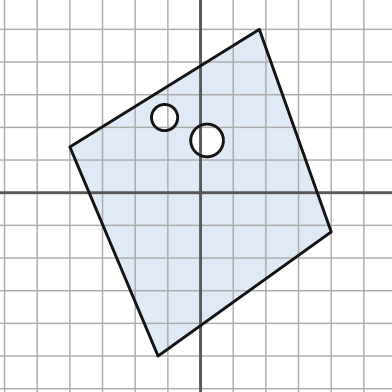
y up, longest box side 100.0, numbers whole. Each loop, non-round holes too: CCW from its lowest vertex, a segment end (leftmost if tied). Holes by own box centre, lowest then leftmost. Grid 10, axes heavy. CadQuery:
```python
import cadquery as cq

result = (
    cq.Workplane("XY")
    .moveTo(-13.0, -50.0)
    .lineTo(40.0, -12.0)
    .lineTo(18.0, 50.0)
    .lineTo(-40.0, 14.0)
    .close()
    .moveTo(2.0, 16.0)
    .circle(5.0)
    .moveTo(-11.0, 23.0)
    .circle(4.0)
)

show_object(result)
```